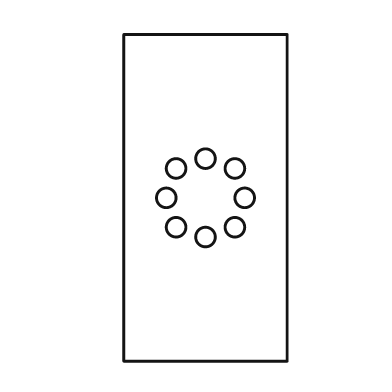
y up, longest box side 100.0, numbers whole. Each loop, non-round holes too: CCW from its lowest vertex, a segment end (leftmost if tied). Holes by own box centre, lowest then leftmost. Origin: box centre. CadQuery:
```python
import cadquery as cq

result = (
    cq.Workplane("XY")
    .moveTo(-25.0, -50.0)
    .lineTo(25.0, -50.0)
    .lineTo(25.0, 50.0)
    .lineTo(-25.0, 50.0)
    .close()
    .moveTo(0.0, -12.0)
    .circle(3.0)
    .moveTo(-9.0, -9.0)
    .circle(3.0)
    .moveTo(9.0, -9.0)
    .circle(3.0)
    .moveTo(-12.0, 0.0)
    .circle(3.0)
    .moveTo(12.0, 0.0)
    .circle(3.0)
    .moveTo(-9.0, 9.0)
    .circle(3.0)
    .moveTo(9.0, 9.0)
    .circle(3.0)
    .moveTo(0.0, 12.0)
    .circle(3.0)
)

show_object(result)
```